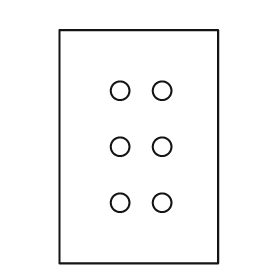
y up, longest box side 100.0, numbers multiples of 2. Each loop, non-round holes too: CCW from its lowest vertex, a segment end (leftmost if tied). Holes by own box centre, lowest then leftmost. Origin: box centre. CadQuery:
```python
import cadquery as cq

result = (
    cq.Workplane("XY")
    .moveTo(-34.0, -50.0)
    .lineTo(34.0, -50.0)
    .lineTo(34.0, 50.0)
    .lineTo(-34.0, 50.0)
    .close()
    .moveTo(-8.0, -24.0)
    .circle(4.0)
    .moveTo(10.0, -24.0)
    .circle(4.0)
    .moveTo(-8.0, 0.0)
    .circle(4.0)
    .moveTo(10.0, 0.0)
    .circle(4.0)
    .moveTo(-8.0, 24.0)
    .circle(4.0)
    .moveTo(10.0, 24.0)
    .circle(4.0)
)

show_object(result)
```